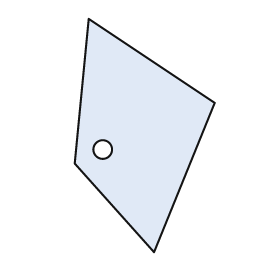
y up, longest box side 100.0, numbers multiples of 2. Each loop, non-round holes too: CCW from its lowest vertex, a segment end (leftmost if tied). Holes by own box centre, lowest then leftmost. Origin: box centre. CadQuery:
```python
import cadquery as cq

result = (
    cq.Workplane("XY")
    .moveTo(4.0, -50.0)
    .lineTo(30.0, 14.0)
    .lineTo(-24.0, 50.0)
    .lineTo(-30.0, -12.0)
    .close()
    .moveTo(-18.0, -6.0)
    .circle(4.0)
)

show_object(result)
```